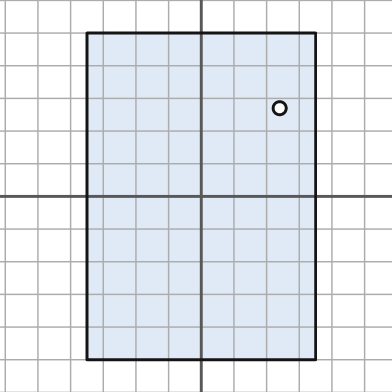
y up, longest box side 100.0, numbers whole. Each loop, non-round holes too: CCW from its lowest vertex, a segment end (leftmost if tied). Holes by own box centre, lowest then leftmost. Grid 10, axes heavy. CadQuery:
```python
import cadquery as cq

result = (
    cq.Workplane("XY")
    .moveTo(-35.0, -50.0)
    .lineTo(35.0, -50.0)
    .lineTo(35.0, 50.0)
    .lineTo(-35.0, 50.0)
    .close()
    .moveTo(24.0, 27.0)
    .circle(2.0)
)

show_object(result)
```